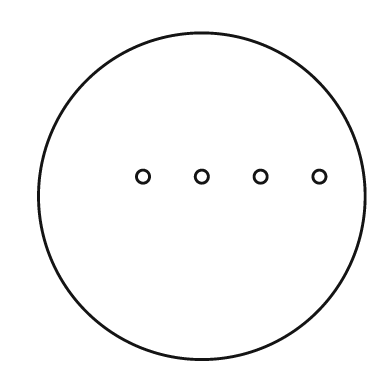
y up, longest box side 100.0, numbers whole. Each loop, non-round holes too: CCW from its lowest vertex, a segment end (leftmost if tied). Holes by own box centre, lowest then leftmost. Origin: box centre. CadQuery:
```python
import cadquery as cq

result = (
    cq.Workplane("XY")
    .moveTo(0.0, 0.0)
    .circle(50.0)
    .moveTo(-18.0, 6.0)
    .circle(2.0)
    .moveTo(0.0, 6.0)
    .circle(2.0)
    .moveTo(18.0, 6.0)
    .circle(2.0)
    .moveTo(36.0, 6.0)
    .circle(2.0)
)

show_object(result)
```